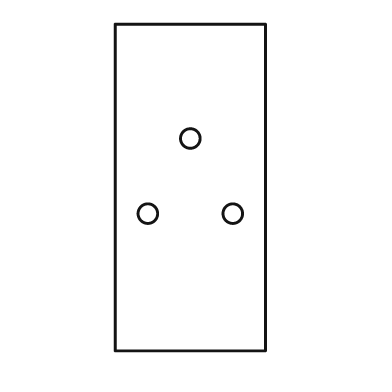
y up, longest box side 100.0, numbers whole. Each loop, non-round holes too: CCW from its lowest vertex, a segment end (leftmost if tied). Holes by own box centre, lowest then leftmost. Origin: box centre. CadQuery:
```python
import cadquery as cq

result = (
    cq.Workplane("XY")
    .moveTo(-23.0, -50.0)
    .lineTo(23.0, -50.0)
    .lineTo(23.0, 50.0)
    .lineTo(-23.0, 50.0)
    .close()
    .moveTo(-13.0, -8.0)
    .circle(3.0)
    .moveTo(13.0, -8.0)
    .circle(3.0)
    .moveTo(0.0, 15.0)
    .circle(3.0)
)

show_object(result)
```